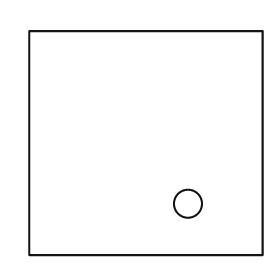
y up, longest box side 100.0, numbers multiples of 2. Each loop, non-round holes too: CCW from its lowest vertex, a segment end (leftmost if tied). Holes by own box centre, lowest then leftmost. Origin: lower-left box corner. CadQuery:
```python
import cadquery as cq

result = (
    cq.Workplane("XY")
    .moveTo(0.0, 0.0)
    .lineTo(100.0, 0.0)
    .lineTo(100.0, 96.0)
    .lineTo(0.0, 96.0)
    .close()
    .moveTo(68.0, 22.0)
    .circle(6.0)
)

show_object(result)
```